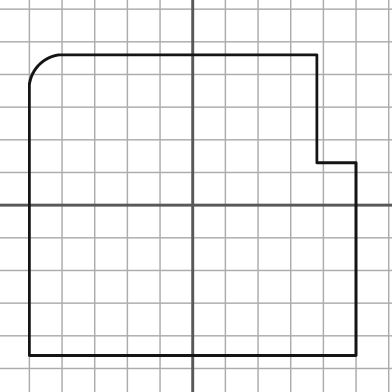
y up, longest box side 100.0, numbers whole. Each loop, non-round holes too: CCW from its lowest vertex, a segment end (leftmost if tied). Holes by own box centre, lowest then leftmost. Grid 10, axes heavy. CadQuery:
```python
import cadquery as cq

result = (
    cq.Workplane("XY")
    .moveTo(-50.0, -46.0)
    .lineTo(50.0, -46.0)
    .lineTo(50.0, 13.0)
    .lineTo(38.0, 13.0)
    .lineTo(38.0, 46.0)
    .lineTo(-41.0, 46.0)
    .threePointArc((-47.0, 43.0), (-50.0, 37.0))
    .close()
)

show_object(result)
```